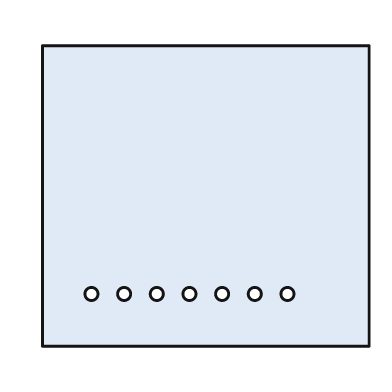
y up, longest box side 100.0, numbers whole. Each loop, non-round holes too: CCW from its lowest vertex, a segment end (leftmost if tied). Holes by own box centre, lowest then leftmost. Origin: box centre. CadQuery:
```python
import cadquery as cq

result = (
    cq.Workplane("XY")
    .moveTo(-50.0, -46.0)
    .lineTo(50.0, -46.0)
    .lineTo(50.0, 46.0)
    .lineTo(-50.0, 46.0)
    .close()
    .moveTo(-35.0, -30.0)
    .circle(2.0)
    .moveTo(-25.0, -30.0)
    .circle(2.0)
    .moveTo(-15.0, -30.0)
    .circle(2.0)
    .moveTo(-5.0, -30.0)
    .circle(2.0)
    .moveTo(5.0, -30.0)
    .circle(2.0)
    .moveTo(15.0, -30.0)
    .circle(2.0)
    .moveTo(25.0, -30.0)
    .circle(2.0)
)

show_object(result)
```